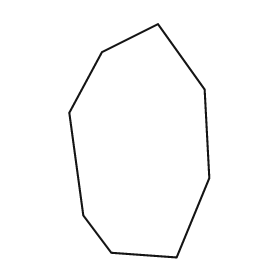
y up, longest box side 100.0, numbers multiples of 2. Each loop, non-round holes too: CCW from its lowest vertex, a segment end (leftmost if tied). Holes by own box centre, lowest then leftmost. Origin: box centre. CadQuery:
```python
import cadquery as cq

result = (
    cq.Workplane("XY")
    .moveTo(16.0, -50.0)
    .lineTo(30.0, -16.0)
    .lineTo(28.0, 22.0)
    .lineTo(8.0, 50.0)
    .lineTo(-16.0, 38.0)
    .lineTo(-30.0, 12.0)
    .lineTo(-24.0, -32.0)
    .lineTo(-12.0, -48.0)
    .close()
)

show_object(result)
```